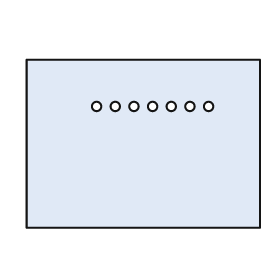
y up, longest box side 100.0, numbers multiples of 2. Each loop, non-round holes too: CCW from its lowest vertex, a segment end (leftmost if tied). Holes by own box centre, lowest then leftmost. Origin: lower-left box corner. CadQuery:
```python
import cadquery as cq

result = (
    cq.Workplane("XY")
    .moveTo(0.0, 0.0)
    .lineTo(100.0, 0.0)
    .lineTo(100.0, 72.0)
    .lineTo(0.0, 72.0)
    .close()
    .moveTo(30.0, 52.0)
    .circle(2.0)
    .moveTo(38.0, 52.0)
    .circle(2.0)
    .moveTo(46.0, 52.0)
    .circle(2.0)
    .moveTo(54.0, 52.0)
    .circle(2.0)
    .moveTo(62.0, 52.0)
    .circle(2.0)
    .moveTo(70.0, 52.0)
    .circle(2.0)
    .moveTo(78.0, 52.0)
    .circle(2.0)
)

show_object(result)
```